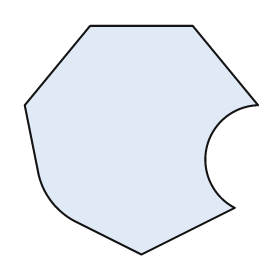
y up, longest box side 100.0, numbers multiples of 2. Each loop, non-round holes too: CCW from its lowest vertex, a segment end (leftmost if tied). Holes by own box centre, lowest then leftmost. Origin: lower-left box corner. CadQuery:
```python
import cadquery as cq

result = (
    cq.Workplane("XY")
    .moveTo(50.0, 0.0)
    .lineTo(90.0, 20.0)
    .threePointArc((78.0, 46.0), (100.0, 64.0))
    .lineTo(72.0, 98.0)
    .lineTo(28.0, 98.0)
    .lineTo(0.0, 64.0)
    .lineTo(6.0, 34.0)
    .threePointArc((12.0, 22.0), (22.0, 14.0))
    .close()
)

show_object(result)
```